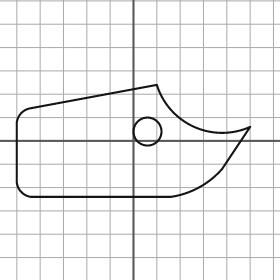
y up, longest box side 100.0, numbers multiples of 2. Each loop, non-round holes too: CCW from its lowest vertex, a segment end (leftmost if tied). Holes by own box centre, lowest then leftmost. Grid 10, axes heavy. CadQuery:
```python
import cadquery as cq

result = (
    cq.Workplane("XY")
    .moveTo(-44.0, -24.0)
    .lineTo(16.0, -24.0)
    .threePointArc((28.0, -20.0), (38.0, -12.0))
    .lineTo(50.0, 6.0)
    .threePointArc((26.0, 6.0), (10.0, 24.0))
    .lineTo(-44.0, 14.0)
    .threePointArc((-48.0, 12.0), (-50.0, 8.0))
    .lineTo(-50.0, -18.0)
    .threePointArc((-48.0, -22.0), (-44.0, -24.0))
    .close()
    .moveTo(6.0, 4.0)
    .circle(6.0)
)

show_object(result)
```